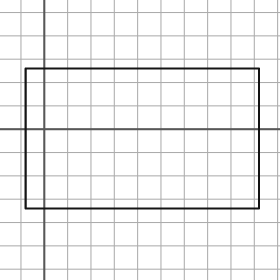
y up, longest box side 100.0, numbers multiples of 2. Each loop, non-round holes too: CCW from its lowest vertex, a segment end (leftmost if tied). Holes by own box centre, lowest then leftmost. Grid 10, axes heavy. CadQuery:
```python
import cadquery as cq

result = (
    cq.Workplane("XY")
    .moveTo(-8.0, -34.0)
    .lineTo(92.0, -34.0)
    .lineTo(92.0, 26.0)
    .lineTo(-8.0, 26.0)
    .close()
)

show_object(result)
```